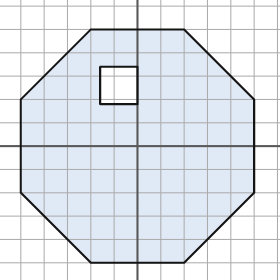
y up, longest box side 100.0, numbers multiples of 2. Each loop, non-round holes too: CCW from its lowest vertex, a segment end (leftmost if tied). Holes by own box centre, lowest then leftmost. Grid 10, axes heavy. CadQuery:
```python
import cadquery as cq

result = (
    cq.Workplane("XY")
    .moveTo(-20.0, -50.0)
    .lineTo(20.0, -50.0)
    .lineTo(50.0, -20.0)
    .lineTo(50.0, 20.0)
    .lineTo(20.0, 50.0)
    .lineTo(-20.0, 50.0)
    .lineTo(-50.0, 20.0)
    .lineTo(-50.0, -20.0)
    .close()
    .moveTo(-16.0, 18.0)
    .lineTo(0.0, 18.0)
    .lineTo(0.0, 34.0)
    .lineTo(-16.0, 34.0)
    .close()
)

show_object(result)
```